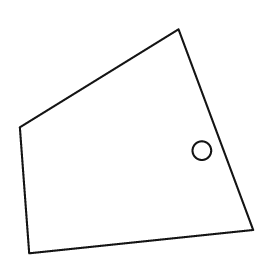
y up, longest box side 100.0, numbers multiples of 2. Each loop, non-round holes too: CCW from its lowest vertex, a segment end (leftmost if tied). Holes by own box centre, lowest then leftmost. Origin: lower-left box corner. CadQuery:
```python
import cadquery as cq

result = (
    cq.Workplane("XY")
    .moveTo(4.0, 0.0)
    .lineTo(100.0, 10.0)
    .lineTo(68.0, 96.0)
    .lineTo(0.0, 54.0)
    .close()
    .moveTo(78.0, 44.0)
    .circle(4.0)
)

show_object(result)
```